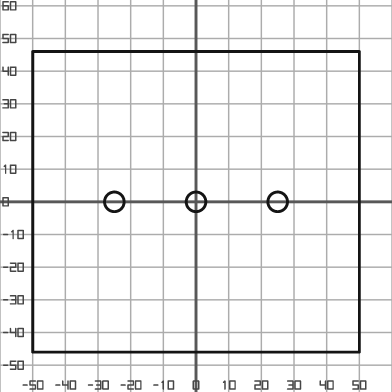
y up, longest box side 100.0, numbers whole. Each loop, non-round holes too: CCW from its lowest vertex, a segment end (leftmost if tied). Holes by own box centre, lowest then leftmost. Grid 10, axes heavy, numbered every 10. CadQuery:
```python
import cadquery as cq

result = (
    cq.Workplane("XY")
    .moveTo(-50.0, -46.0)
    .lineTo(50.0, -46.0)
    .lineTo(50.0, 46.0)
    .lineTo(-50.0, 46.0)
    .close()
    .moveTo(-25.0, 0.0)
    .circle(3.0)
    .moveTo(0.0, 0.0)
    .circle(3.0)
    .moveTo(25.0, 0.0)
    .circle(3.0)
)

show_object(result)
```